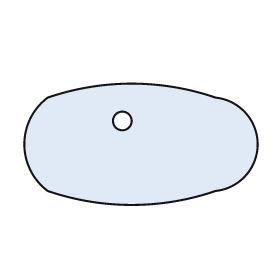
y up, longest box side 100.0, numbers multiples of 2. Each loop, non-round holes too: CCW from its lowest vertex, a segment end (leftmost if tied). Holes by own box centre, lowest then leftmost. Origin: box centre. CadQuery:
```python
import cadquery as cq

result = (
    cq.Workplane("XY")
    .moveTo(-40.0, -20.0)
    .threePointArc((-4.0, -26.0), (32.0, -20.0))
    .threePointArc((50.0, 0.0), (32.0, 20.0))
    .threePointArc((-4.0, 26.0), (-40.0, 20.0))
    .threePointArc((-50.0, 0.0), (-40.0, -20.0))
    .close()
    .moveTo(-8.0, 10.0)
    .circle(4.0)
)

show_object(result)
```